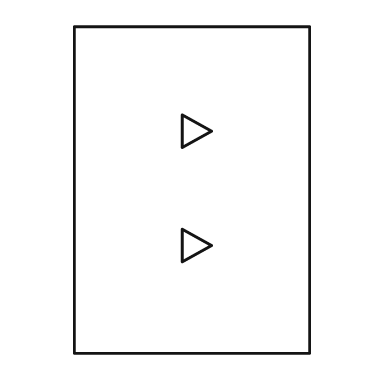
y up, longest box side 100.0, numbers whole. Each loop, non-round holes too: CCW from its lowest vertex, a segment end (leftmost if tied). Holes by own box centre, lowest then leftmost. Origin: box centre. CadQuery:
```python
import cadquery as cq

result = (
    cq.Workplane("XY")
    .moveTo(-36.0, -50.0)
    .lineTo(36.0, -50.0)
    .lineTo(36.0, 50.0)
    .lineTo(-36.0, 50.0)
    .close()
    .moveTo(-3.0, -22.0)
    .lineTo(6.0, -17.0)
    .lineTo(-3.0, -12.0)
    .close()
    .moveTo(-3.0, 13.0)
    .lineTo(6.0, 18.0)
    .lineTo(-3.0, 23.0)
    .close()
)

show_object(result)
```